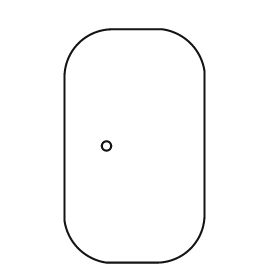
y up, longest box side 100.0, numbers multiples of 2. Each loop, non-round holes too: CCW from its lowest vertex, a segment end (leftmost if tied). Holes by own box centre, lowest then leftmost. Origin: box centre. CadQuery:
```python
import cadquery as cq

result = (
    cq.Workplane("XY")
    .moveTo(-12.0, -50.0)
    .lineTo(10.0, -50.0)
    .threePointArc((24.0, -44.0), (30.0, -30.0))
    .lineTo(30.0, 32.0)
    .threePointArc((24.0, 44.0), (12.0, 50.0))
    .lineTo(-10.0, 50.0)
    .threePointArc((-24.0, 44.0), (-30.0, 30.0))
    .lineTo(-30.0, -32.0)
    .threePointArc((-24.0, -44.0), (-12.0, -50.0))
    .close()
    .moveTo(-12.0, 0.0)
    .circle(2.0)
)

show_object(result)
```